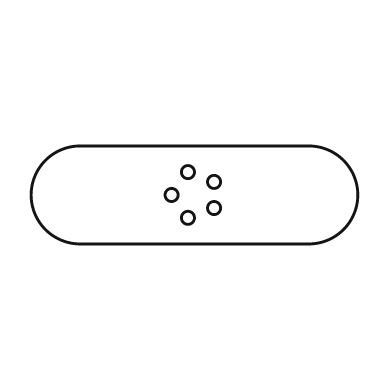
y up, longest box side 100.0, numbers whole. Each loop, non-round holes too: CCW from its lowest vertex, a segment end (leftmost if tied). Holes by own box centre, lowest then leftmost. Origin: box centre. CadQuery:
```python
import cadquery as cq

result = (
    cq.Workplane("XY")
    .moveTo(-35.0, -15.0)
    .lineTo(35.0, -15.0)
    .threePointArc((50.0, 0.0), (35.0, 15.0))
    .lineTo(-35.0, 15.0)
    .threePointArc((-50.0, 0.0), (-35.0, -15.0))
    .close()
    .moveTo(-2.0, -7.0)
    .circle(2.0)
    .moveTo(6.0, -4.0)
    .circle(2.0)
    .moveTo(-7.0, 0.0)
    .circle(2.0)
    .moveTo(6.0, 4.0)
    .circle(2.0)
    .moveTo(-2.0, 7.0)
    .circle(2.0)
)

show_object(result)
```